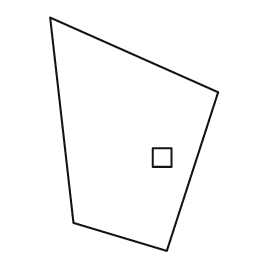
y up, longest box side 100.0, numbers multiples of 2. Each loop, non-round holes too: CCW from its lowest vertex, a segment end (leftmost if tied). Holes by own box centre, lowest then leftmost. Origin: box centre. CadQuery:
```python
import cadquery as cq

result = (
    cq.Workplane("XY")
    .moveTo(14.0, -50.0)
    .lineTo(36.0, 18.0)
    .lineTo(-36.0, 50.0)
    .lineTo(-26.0, -38.0)
    .close()
    .moveTo(8.0, -14.0)
    .lineTo(16.0, -14.0)
    .lineTo(16.0, -6.0)
    .lineTo(8.0, -6.0)
    .close()
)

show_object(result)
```